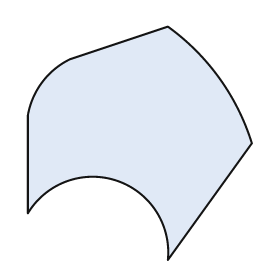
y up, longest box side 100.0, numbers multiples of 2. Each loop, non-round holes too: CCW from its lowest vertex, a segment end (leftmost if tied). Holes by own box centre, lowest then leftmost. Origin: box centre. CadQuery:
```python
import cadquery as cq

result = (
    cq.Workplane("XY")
    .moveTo(12.0, -50.0)
    .lineTo(48.0, 0.0)
    .threePointArc((34.0, 28.0), (12.0, 50.0))
    .lineTo(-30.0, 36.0)
    .threePointArc((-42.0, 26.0), (-48.0, 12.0))
    .lineTo(-48.0, -30.0)
    .threePointArc((-10.0, -16.0), (12.0, -50.0))
    .close()
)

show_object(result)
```